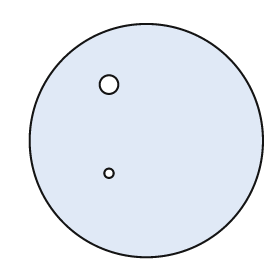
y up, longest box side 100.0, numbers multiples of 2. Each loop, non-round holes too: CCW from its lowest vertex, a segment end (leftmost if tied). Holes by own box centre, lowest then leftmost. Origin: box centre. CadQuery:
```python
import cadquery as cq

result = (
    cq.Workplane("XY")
    .moveTo(0.0, 0.0)
    .circle(50.0)
    .moveTo(-16.0, -14.0)
    .circle(2.0)
    .moveTo(-16.0, 24.0)
    .circle(4.0)
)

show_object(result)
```